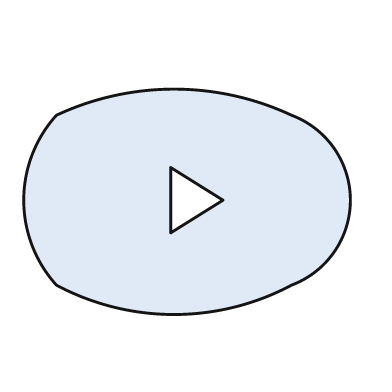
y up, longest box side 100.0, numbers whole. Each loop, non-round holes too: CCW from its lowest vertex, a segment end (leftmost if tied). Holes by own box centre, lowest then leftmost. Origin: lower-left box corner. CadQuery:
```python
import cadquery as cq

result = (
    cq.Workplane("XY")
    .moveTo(10.0, 9.0)
    .threePointArc((46.0, 0.0), (82.0, 9.0))
    .threePointArc((100.0, 35.0), (82.0, 61.0))
    .threePointArc((46.0, 69.0), (10.0, 61.0))
    .threePointArc((0.0, 35.0), (10.0, 9.0))
    .close()
    .moveTo(45.0, 25.0)
    .lineTo(61.0, 35.0)
    .lineTo(45.0, 45.0)
    .close()
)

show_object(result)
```